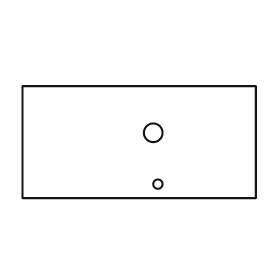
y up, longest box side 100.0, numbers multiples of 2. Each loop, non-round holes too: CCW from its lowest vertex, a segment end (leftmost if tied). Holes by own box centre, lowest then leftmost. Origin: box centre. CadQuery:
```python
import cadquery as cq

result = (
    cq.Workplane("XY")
    .moveTo(-50.0, -24.0)
    .lineTo(50.0, -24.0)
    .lineTo(50.0, 24.0)
    .lineTo(-50.0, 24.0)
    .close()
    .moveTo(8.0, -18.0)
    .circle(2.0)
    .moveTo(6.0, 4.0)
    .circle(4.0)
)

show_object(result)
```